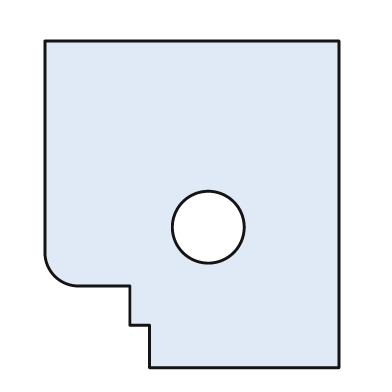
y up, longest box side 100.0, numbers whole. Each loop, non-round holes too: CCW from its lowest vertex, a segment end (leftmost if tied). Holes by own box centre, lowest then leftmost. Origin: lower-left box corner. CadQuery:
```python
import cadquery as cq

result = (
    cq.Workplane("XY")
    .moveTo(32.0, 0.0)
    .lineTo(90.0, 0.0)
    .lineTo(90.0, 100.0)
    .lineTo(0.0, 100.0)
    .lineTo(0.0, 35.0)
    .threePointArc((3.0, 28.0), (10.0, 25.0))
    .lineTo(26.0, 25.0)
    .lineTo(26.0, 13.0)
    .lineTo(32.0, 13.0)
    .close()
    .moveTo(50.0, 43.0)
    .circle(11.0)
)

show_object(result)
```